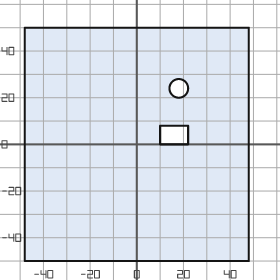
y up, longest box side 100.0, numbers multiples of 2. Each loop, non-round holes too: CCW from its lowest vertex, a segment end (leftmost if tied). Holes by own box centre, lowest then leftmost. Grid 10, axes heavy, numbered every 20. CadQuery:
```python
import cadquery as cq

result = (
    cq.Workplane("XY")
    .moveTo(-48.0, -50.0)
    .lineTo(48.0, -50.0)
    .lineTo(48.0, 50.0)
    .lineTo(-48.0, 50.0)
    .close()
    .moveTo(10.0, 0.0)
    .lineTo(22.0, 0.0)
    .lineTo(22.0, 8.0)
    .lineTo(10.0, 8.0)
    .close()
    .moveTo(18.0, 24.0)
    .circle(4.0)
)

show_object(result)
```